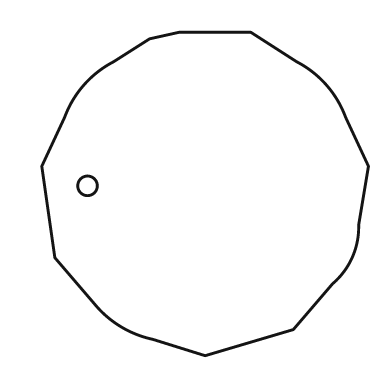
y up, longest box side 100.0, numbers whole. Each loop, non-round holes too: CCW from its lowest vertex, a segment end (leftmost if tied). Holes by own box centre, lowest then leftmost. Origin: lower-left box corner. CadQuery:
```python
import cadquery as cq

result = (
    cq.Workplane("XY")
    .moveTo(50.0, 0.0)
    .lineTo(77.0, 8.0)
    .lineTo(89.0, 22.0)
    .threePointArc((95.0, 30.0), (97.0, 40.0))
    .lineTo(100.0, 58.0)
    .lineTo(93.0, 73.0)
    .threePointArc((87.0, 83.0), (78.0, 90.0))
    .lineTo(64.0, 99.0)
    .lineTo(42.0, 99.0)
    .lineTo(33.0, 97.0)
    .lineTo(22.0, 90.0)
    .threePointArc((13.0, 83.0), (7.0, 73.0))
    .lineTo(0.0, 58.0)
    .lineTo(4.0, 30.0)
    .lineTo(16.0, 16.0)
    .threePointArc((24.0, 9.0), (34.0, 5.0))
    .close()
    .moveTo(14.0, 52.0)
    .circle(3.0)
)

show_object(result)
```